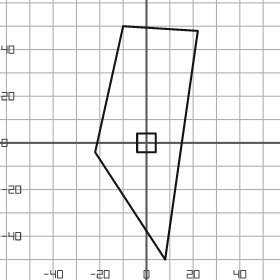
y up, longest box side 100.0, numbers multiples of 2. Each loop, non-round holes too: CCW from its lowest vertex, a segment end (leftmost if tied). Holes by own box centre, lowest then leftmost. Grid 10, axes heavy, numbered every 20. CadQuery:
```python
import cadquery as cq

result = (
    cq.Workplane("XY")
    .moveTo(8.0, -50.0)
    .lineTo(22.0, 48.0)
    .lineTo(-10.0, 50.0)
    .lineTo(-22.0, -4.0)
    .close()
    .moveTo(-4.0, -4.0)
    .lineTo(4.0, -4.0)
    .lineTo(4.0, 4.0)
    .lineTo(-4.0, 4.0)
    .close()
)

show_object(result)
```